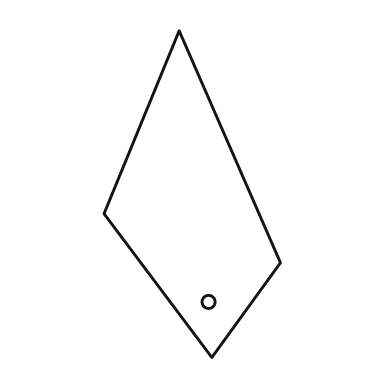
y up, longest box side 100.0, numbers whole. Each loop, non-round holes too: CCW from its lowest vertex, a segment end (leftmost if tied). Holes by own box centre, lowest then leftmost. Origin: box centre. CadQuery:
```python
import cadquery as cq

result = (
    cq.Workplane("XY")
    .moveTo(6.0, -50.0)
    .lineTo(27.0, -21.0)
    .lineTo(-4.0, 50.0)
    .lineTo(-27.0, -6.0)
    .close()
    .moveTo(5.0, -33.0)
    .circle(2.0)
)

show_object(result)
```